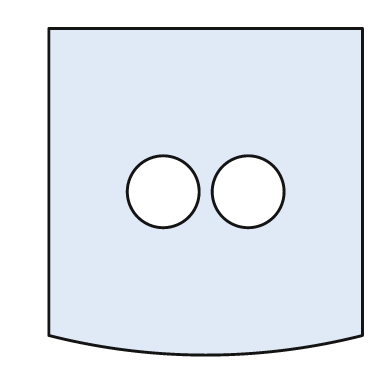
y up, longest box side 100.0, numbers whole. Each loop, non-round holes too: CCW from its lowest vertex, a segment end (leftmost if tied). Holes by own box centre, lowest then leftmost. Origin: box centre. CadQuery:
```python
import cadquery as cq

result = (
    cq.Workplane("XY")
    .moveTo(-48.0, -44.0)
    .threePointArc((0.0, -50.0), (48.0, -44.0))
    .lineTo(48.0, 50.0)
    .lineTo(-48.0, 50.0)
    .close()
    .moveTo(-13.0, 0.0)
    .circle(11.0)
    .moveTo(13.0, 0.0)
    .circle(11.0)
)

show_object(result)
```